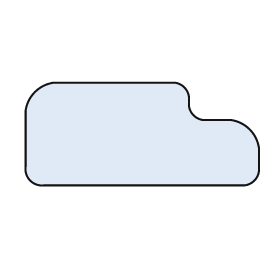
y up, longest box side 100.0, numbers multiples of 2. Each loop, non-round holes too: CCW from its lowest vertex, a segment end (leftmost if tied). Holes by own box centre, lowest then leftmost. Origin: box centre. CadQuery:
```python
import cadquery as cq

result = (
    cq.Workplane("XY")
    .moveTo(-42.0, -22.0)
    .lineTo(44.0, -22.0)
    .threePointArc((48.0, -20.0), (50.0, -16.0))
    .lineTo(50.0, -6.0)
    .threePointArc((46.0, 2.0), (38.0, 6.0))
    .lineTo(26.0, 6.0)
    .threePointArc((22.0, 8.0), (20.0, 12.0))
    .lineTo(20.0, 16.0)
    .threePointArc((18.0, 20.0), (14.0, 22.0))
    .lineTo(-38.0, 22.0)
    .threePointArc((-46.0, 18.0), (-50.0, 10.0))
    .lineTo(-50.0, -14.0)
    .threePointArc((-48.0, -20.0), (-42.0, -22.0))
    .close()
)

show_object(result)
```